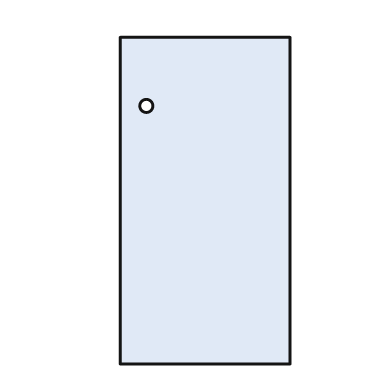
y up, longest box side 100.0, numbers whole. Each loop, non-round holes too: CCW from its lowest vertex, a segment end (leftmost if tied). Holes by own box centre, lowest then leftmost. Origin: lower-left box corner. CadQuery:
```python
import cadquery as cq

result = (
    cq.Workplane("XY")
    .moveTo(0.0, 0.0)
    .lineTo(52.0, 0.0)
    .lineTo(52.0, 100.0)
    .lineTo(0.0, 100.0)
    .close()
    .moveTo(8.0, 79.0)
    .circle(2.0)
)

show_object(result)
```